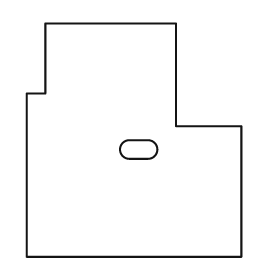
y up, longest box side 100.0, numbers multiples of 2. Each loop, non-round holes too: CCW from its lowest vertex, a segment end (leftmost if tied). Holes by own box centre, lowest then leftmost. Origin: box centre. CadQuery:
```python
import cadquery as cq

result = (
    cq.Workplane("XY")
    .moveTo(-46.0, -50.0)
    .lineTo(46.0, -50.0)
    .lineTo(46.0, 6.0)
    .lineTo(18.0, 6.0)
    .lineTo(18.0, 50.0)
    .lineTo(-38.0, 50.0)
    .lineTo(-38.0, 20.0)
    .lineTo(-46.0, 20.0)
    .close()
    .moveTo(-2.0, -8.0)
    .lineTo(6.0, -8.0)
    .threePointArc((10.0, -4.0), (6.0, 0.0))
    .lineTo(-2.0, 0.0)
    .threePointArc((-6.0, -4.0), (-2.0, -8.0))
    .close()
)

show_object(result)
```